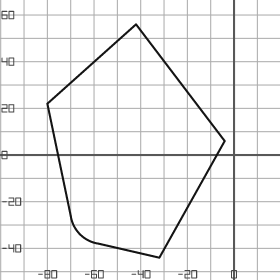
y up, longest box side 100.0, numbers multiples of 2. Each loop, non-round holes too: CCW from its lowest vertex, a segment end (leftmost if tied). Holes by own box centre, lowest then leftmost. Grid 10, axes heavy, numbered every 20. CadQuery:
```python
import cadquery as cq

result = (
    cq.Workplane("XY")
    .moveTo(-32.0, -44.0)
    .lineTo(-4.0, 6.0)
    .lineTo(-42.0, 56.0)
    .lineTo(-80.0, 22.0)
    .lineTo(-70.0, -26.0)
    .threePointArc((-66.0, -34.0), (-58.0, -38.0))
    .close()
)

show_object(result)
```